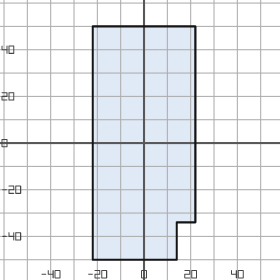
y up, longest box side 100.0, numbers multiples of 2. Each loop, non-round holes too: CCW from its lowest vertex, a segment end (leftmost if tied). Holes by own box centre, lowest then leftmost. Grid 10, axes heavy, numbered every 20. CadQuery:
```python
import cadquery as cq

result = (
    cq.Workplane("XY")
    .moveTo(-22.0, -50.0)
    .lineTo(14.0, -50.0)
    .lineTo(14.0, -34.0)
    .lineTo(22.0, -34.0)
    .lineTo(22.0, 50.0)
    .lineTo(-22.0, 50.0)
    .close()
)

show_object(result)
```